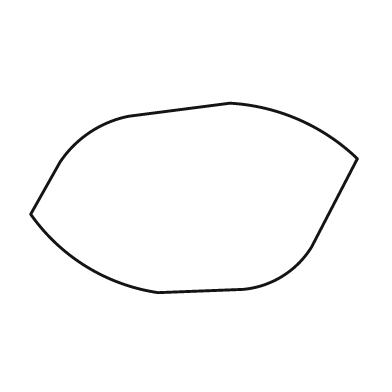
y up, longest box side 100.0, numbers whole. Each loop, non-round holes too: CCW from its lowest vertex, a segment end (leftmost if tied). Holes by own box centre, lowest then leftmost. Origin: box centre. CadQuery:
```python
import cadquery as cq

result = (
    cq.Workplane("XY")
    .moveTo(-11.0, -29.0)
    .lineTo(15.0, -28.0)
    .threePointArc((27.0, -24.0), (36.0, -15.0))
    .lineTo(50.0, 12.0)
    .threePointArc((32.0, 24.0), (11.0, 29.0))
    .lineTo(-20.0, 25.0)
    .threePointArc((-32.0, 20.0), (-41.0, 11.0))
    .lineTo(-50.0, -5.0)
    .threePointArc((-33.0, -21.0), (-11.0, -29.0))
    .close()
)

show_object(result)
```